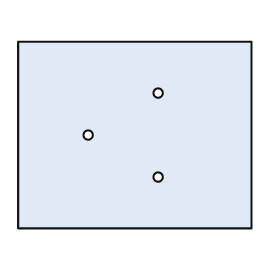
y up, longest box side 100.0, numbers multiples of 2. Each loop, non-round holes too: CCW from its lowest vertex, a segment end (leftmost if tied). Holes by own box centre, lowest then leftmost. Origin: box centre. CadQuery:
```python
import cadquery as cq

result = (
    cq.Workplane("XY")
    .moveTo(-50.0, -40.0)
    .lineTo(50.0, -40.0)
    .lineTo(50.0, 40.0)
    .lineTo(-50.0, 40.0)
    .close()
    .moveTo(10.0, -18.0)
    .circle(2.0)
    .moveTo(-20.0, 0.0)
    .circle(2.0)
    .moveTo(10.0, 18.0)
    .circle(2.0)
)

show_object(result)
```